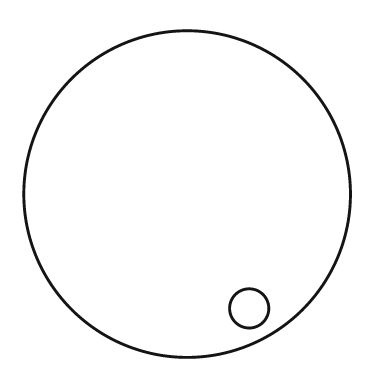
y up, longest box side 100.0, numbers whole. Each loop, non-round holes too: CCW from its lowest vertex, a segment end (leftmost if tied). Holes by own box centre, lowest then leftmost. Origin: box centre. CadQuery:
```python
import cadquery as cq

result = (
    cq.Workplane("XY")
    .moveTo(0.0, 0.0)
    .circle(50.0)
    .moveTo(19.0, -35.0)
    .circle(6.0)
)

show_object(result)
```